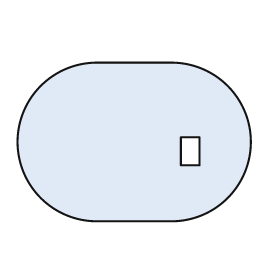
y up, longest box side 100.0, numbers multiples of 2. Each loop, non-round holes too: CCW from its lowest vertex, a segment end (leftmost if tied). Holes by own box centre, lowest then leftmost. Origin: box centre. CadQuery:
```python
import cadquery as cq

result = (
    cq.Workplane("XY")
    .moveTo(-16.0, -34.0)
    .lineTo(16.0, -34.0)
    .threePointArc((50.0, 0.0), (16.0, 34.0))
    .lineTo(-16.0, 34.0)
    .threePointArc((-50.0, 0.0), (-16.0, -34.0))
    .close()
    .moveTo(20.0, -10.0)
    .lineTo(28.0, -10.0)
    .lineTo(28.0, 2.0)
    .lineTo(20.0, 2.0)
    .close()
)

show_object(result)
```